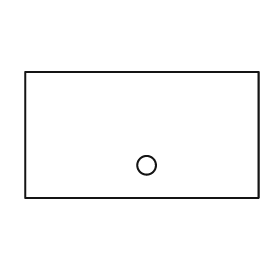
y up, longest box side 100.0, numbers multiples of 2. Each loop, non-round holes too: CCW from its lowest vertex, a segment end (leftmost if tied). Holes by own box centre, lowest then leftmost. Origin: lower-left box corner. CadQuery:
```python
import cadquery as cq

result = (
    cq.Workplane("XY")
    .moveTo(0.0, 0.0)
    .lineTo(100.0, 0.0)
    .lineTo(100.0, 54.0)
    .lineTo(0.0, 54.0)
    .close()
    .moveTo(52.0, 14.0)
    .circle(4.0)
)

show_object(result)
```